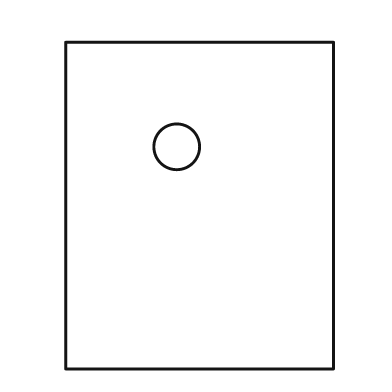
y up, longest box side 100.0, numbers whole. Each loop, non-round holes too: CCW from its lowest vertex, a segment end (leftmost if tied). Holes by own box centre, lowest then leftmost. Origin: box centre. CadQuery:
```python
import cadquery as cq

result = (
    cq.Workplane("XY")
    .moveTo(-41.0, -50.0)
    .lineTo(41.0, -50.0)
    .lineTo(41.0, 50.0)
    .lineTo(-41.0, 50.0)
    .close()
    .moveTo(-7.0, 18.0)
    .circle(7.0)
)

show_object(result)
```